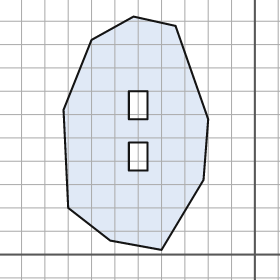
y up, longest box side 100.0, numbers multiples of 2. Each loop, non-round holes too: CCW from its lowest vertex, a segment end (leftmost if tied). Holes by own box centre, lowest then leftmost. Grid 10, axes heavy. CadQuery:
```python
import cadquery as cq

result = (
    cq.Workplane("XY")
    .moveTo(-40.0, 2.0)
    .lineTo(-22.0, 32.0)
    .lineTo(-20.0, 58.0)
    .lineTo(-34.0, 98.0)
    .lineTo(-52.0, 102.0)
    .lineTo(-70.0, 92.0)
    .lineTo(-82.0, 62.0)
    .lineTo(-80.0, 20.0)
    .lineTo(-62.0, 6.0)
    .close()
    .moveTo(-54.0, 36.0)
    .lineTo(-46.0, 36.0)
    .lineTo(-46.0, 48.0)
    .lineTo(-54.0, 48.0)
    .close()
    .moveTo(-54.0, 58.0)
    .lineTo(-46.0, 58.0)
    .lineTo(-46.0, 70.0)
    .lineTo(-54.0, 70.0)
    .close()
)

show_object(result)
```